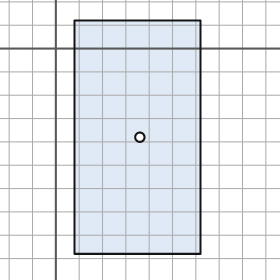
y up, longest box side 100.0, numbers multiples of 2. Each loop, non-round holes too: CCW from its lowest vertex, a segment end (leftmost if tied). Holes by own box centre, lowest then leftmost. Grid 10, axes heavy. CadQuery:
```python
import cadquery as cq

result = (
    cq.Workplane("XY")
    .moveTo(8.0, -88.0)
    .lineTo(62.0, -88.0)
    .lineTo(62.0, 12.0)
    .lineTo(8.0, 12.0)
    .close()
    .moveTo(36.0, -38.0)
    .circle(2.0)
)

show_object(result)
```